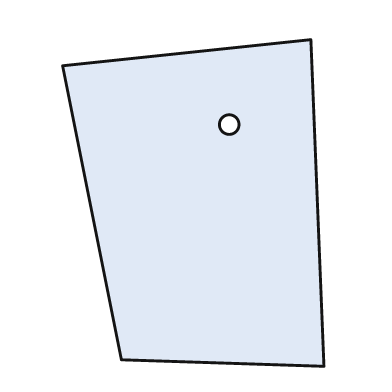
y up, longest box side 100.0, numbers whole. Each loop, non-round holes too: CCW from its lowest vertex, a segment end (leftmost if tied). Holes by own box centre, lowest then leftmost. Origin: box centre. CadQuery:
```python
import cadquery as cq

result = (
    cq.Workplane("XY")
    .moveTo(40.0, -50.0)
    .lineTo(36.0, 50.0)
    .lineTo(-40.0, 42.0)
    .lineTo(-22.0, -48.0)
    .close()
    .moveTo(11.0, 24.0)
    .circle(3.0)
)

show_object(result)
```